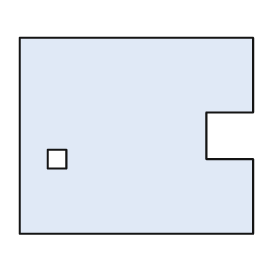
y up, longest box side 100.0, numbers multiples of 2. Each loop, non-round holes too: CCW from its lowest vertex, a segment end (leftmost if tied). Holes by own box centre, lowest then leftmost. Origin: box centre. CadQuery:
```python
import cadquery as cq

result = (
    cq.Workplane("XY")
    .moveTo(-50.0, -42.0)
    .lineTo(50.0, -42.0)
    .lineTo(50.0, -10.0)
    .lineTo(30.0, -10.0)
    .lineTo(30.0, 10.0)
    .lineTo(50.0, 10.0)
    .lineTo(50.0, 42.0)
    .lineTo(-50.0, 42.0)
    .close()
    .moveTo(-38.0, -14.0)
    .lineTo(-30.0, -14.0)
    .lineTo(-30.0, -6.0)
    .lineTo(-38.0, -6.0)
    .close()
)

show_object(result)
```